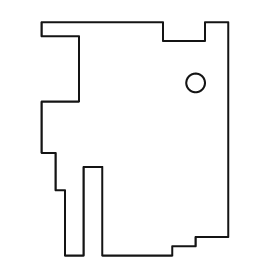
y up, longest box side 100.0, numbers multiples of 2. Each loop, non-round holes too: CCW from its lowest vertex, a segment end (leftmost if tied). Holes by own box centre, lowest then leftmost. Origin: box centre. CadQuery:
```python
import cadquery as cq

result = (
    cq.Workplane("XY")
    .moveTo(-30.0, -50.0)
    .lineTo(-22.0, -50.0)
    .lineTo(-22.0, -12.0)
    .lineTo(-14.0, -12.0)
    .lineTo(-14.0, -50.0)
    .lineTo(16.0, -50.0)
    .lineTo(16.0, -46.0)
    .lineTo(26.0, -46.0)
    .lineTo(26.0, -42.0)
    .lineTo(40.0, -42.0)
    .lineTo(40.0, 50.0)
    .lineTo(30.0, 50.0)
    .lineTo(30.0, 42.0)
    .lineTo(12.0, 42.0)
    .lineTo(12.0, 50.0)
    .lineTo(-40.0, 50.0)
    .lineTo(-40.0, 44.0)
    .lineTo(-24.0, 44.0)
    .lineTo(-24.0, 16.0)
    .lineTo(-40.0, 16.0)
    .lineTo(-40.0, -6.0)
    .lineTo(-34.0, -6.0)
    .lineTo(-34.0, -22.0)
    .lineTo(-30.0, -22.0)
    .close()
    .moveTo(26.0, 24.0)
    .circle(4.0)
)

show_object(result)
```